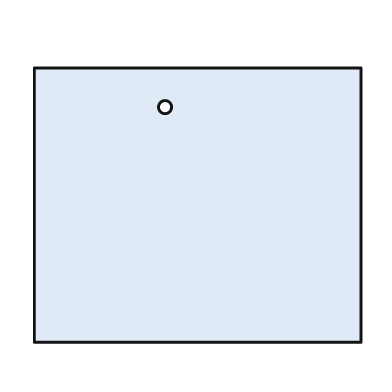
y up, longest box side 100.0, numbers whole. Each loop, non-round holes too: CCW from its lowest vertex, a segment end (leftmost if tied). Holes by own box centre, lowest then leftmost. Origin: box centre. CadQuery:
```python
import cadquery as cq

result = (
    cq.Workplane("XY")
    .moveTo(-50.0, -42.0)
    .lineTo(50.0, -42.0)
    .lineTo(50.0, 42.0)
    .lineTo(-50.0, 42.0)
    .close()
    .moveTo(-10.0, 30.0)
    .circle(2.0)
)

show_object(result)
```